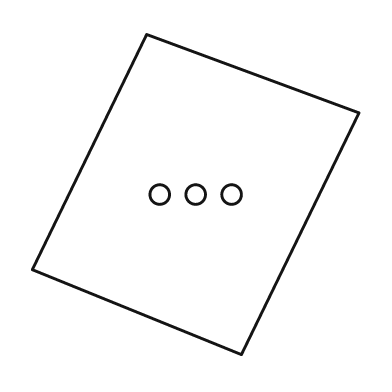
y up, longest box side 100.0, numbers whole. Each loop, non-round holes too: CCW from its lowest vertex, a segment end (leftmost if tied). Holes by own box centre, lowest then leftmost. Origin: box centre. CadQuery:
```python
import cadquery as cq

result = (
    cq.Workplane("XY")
    .moveTo(14.0, -49.0)
    .lineTo(50.0, 25.0)
    .lineTo(-15.0, 49.0)
    .lineTo(-50.0, -23.0)
    .close()
    .moveTo(-11.0, 0.0)
    .circle(3.0)
    .moveTo(0.0, 0.0)
    .circle(3.0)
    .moveTo(11.0, 0.0)
    .circle(3.0)
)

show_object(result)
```